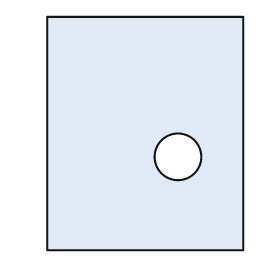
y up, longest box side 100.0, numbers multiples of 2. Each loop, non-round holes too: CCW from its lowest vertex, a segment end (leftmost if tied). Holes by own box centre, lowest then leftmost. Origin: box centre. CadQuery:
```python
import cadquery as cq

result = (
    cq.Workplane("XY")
    .moveTo(-42.0, -50.0)
    .lineTo(42.0, -50.0)
    .lineTo(42.0, 50.0)
    .lineTo(-42.0, 50.0)
    .close()
    .moveTo(14.0, -10.0)
    .circle(10.0)
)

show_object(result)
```